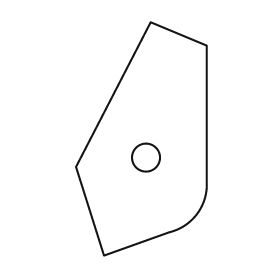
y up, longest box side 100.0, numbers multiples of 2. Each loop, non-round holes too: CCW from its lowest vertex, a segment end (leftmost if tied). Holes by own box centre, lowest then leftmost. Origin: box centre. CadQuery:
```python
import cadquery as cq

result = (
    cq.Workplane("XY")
    .moveTo(-16.0, -50.0)
    .lineTo(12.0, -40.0)
    .threePointArc((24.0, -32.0), (28.0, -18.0))
    .lineTo(28.0, 40.0)
    .lineTo(4.0, 50.0)
    .lineTo(-28.0, -12.0)
    .close()
    .moveTo(2.0, -8.0)
    .circle(6.0)
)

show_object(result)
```